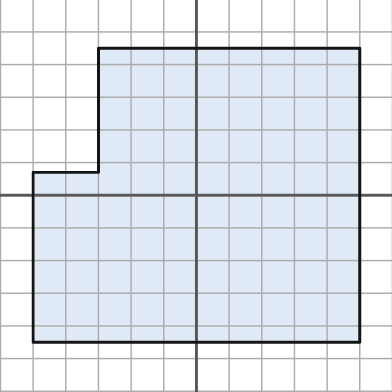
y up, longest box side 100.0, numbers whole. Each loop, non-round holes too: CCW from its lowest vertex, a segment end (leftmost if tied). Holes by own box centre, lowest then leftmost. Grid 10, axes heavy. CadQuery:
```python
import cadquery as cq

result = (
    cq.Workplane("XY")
    .moveTo(-50.0, -45.0)
    .lineTo(50.0, -45.0)
    .lineTo(50.0, 45.0)
    .lineTo(-30.0, 45.0)
    .lineTo(-30.0, 7.0)
    .lineTo(-50.0, 7.0)
    .close()
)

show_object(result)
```